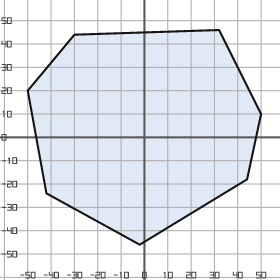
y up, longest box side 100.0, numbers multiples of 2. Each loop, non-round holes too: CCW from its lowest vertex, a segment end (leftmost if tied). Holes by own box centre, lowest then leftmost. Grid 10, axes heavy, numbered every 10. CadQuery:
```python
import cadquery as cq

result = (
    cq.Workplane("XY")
    .moveTo(-2.0, -46.0)
    .lineTo(44.0, -18.0)
    .lineTo(50.0, 10.0)
    .lineTo(32.0, 46.0)
    .lineTo(-30.0, 44.0)
    .lineTo(-50.0, 20.0)
    .lineTo(-42.0, -24.0)
    .close()
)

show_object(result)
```